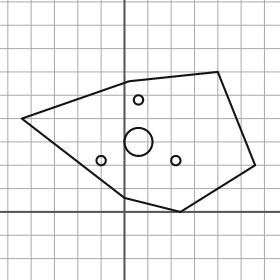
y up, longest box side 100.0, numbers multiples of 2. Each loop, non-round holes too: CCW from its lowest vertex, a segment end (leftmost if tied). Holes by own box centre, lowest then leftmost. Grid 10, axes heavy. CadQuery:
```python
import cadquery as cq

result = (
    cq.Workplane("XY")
    .moveTo(24.0, 0.0)
    .lineTo(56.0, 20.0)
    .lineTo(40.0, 60.0)
    .lineTo(2.0, 56.0)
    .lineTo(-44.0, 40.0)
    .lineTo(0.0, 6.0)
    .close()
    .moveTo(-10.0, 22.0)
    .circle(2.0)
    .moveTo(22.0, 22.0)
    .circle(2.0)
    .moveTo(6.0, 30.0)
    .circle(6.0)
    .moveTo(6.0, 48.0)
    .circle(2.0)
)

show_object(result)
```